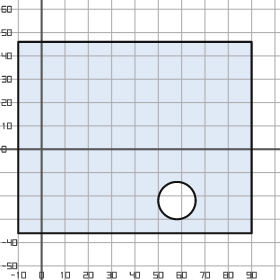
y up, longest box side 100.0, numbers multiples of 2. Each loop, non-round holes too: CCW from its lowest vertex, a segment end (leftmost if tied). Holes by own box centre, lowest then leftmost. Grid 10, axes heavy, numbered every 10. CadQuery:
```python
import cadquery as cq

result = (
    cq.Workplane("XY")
    .moveTo(-10.0, -36.0)
    .lineTo(90.0, -36.0)
    .lineTo(90.0, 46.0)
    .lineTo(-10.0, 46.0)
    .close()
    .moveTo(58.0, -22.0)
    .circle(8.0)
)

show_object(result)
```